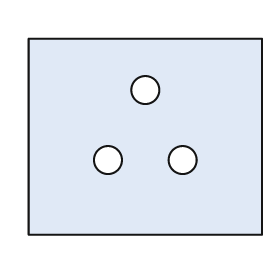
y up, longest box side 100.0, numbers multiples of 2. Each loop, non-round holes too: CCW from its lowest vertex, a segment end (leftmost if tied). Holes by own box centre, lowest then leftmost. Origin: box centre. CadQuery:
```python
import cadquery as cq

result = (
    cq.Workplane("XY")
    .moveTo(-50.0, -42.0)
    .lineTo(50.0, -42.0)
    .lineTo(50.0, 42.0)
    .lineTo(-50.0, 42.0)
    .close()
    .moveTo(-16.0, -10.0)
    .circle(6.0)
    .moveTo(16.0, -10.0)
    .circle(6.0)
    .moveTo(0.0, 20.0)
    .circle(6.0)
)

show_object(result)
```